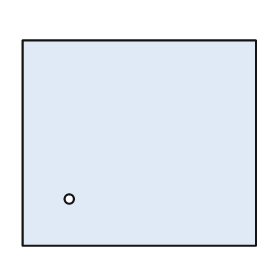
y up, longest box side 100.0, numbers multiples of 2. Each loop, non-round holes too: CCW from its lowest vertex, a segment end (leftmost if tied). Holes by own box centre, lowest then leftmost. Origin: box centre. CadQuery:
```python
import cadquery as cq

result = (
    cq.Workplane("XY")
    .moveTo(-50.0, -44.0)
    .lineTo(50.0, -44.0)
    .lineTo(50.0, 44.0)
    .lineTo(-50.0, 44.0)
    .close()
    .moveTo(-30.0, -24.0)
    .circle(2.0)
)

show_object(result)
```